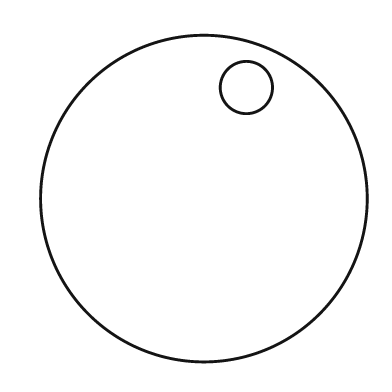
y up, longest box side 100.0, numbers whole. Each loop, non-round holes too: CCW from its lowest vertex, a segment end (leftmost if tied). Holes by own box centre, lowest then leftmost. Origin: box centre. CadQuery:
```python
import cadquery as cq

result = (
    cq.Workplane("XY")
    .moveTo(0.0, 0.0)
    .circle(50.0)
    .moveTo(13.0, 34.0)
    .circle(8.0)
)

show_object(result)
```